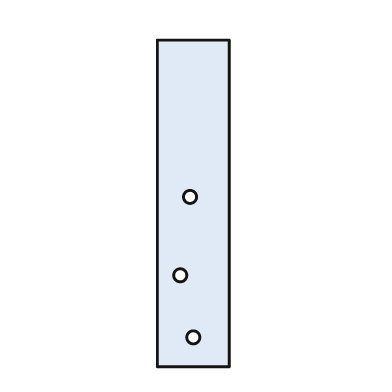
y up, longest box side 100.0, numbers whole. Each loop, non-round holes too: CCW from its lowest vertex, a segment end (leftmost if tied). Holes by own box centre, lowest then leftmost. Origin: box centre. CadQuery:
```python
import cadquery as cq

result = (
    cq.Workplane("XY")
    .moveTo(-11.0, -50.0)
    .lineTo(11.0, -50.0)
    .lineTo(11.0, 50.0)
    .lineTo(-11.0, 50.0)
    .close()
    .moveTo(0.0, -41.0)
    .circle(2.0)
    .moveTo(-4.0, -22.0)
    .circle(2.0)
    .moveTo(-1.0, 2.0)
    .circle(2.0)
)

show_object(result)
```